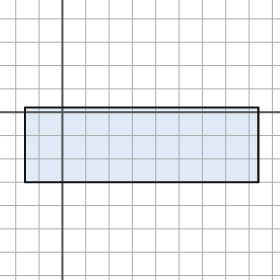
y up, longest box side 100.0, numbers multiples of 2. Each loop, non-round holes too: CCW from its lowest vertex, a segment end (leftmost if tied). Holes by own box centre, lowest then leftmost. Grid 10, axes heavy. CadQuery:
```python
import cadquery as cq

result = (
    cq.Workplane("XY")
    .moveTo(-16.0, -30.0)
    .lineTo(84.0, -30.0)
    .lineTo(84.0, 2.0)
    .lineTo(-16.0, 2.0)
    .close()
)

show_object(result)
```